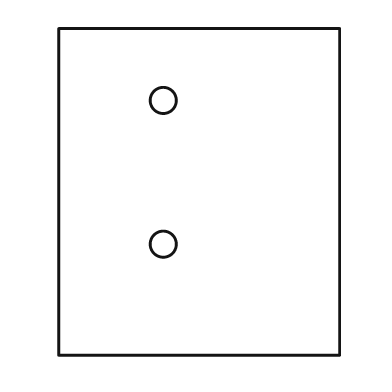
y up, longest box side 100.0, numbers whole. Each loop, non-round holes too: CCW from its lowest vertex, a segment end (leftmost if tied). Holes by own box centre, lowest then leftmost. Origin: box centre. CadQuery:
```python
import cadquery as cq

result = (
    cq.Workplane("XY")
    .moveTo(-43.0, -50.0)
    .lineTo(43.0, -50.0)
    .lineTo(43.0, 50.0)
    .lineTo(-43.0, 50.0)
    .close()
    .moveTo(-11.0, -16.0)
    .circle(4.0)
    .moveTo(-11.0, 28.0)
    .circle(4.0)
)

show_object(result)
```